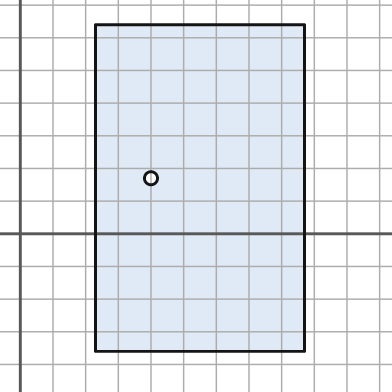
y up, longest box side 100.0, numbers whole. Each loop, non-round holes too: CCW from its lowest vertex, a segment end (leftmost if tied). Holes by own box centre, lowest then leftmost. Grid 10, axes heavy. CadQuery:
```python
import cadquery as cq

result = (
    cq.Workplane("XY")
    .moveTo(23.0, -36.0)
    .lineTo(87.0, -36.0)
    .lineTo(87.0, 64.0)
    .lineTo(23.0, 64.0)
    .close()
    .moveTo(40.0, 17.0)
    .circle(2.0)
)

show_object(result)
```